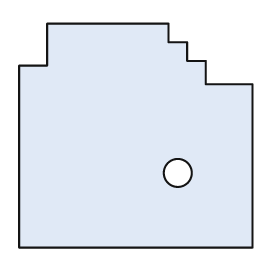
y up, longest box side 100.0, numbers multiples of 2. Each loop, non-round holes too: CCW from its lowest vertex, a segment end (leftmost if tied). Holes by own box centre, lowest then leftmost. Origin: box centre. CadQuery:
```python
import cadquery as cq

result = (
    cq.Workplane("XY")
    .moveTo(-50.0, -48.0)
    .lineTo(50.0, -48.0)
    .lineTo(50.0, 22.0)
    .lineTo(30.0, 22.0)
    .lineTo(30.0, 32.0)
    .lineTo(22.0, 32.0)
    .lineTo(22.0, 40.0)
    .lineTo(14.0, 40.0)
    .lineTo(14.0, 48.0)
    .lineTo(-38.0, 48.0)
    .lineTo(-38.0, 30.0)
    .lineTo(-50.0, 30.0)
    .close()
    .moveTo(18.0, -16.0)
    .circle(6.0)
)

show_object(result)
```